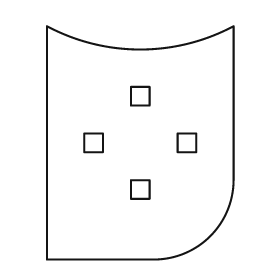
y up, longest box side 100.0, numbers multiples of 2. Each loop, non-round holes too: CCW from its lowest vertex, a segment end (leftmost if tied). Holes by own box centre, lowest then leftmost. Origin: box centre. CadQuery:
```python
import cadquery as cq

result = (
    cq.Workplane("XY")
    .moveTo(-40.0, -50.0)
    .lineTo(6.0, -50.0)
    .threePointArc((30.0, -40.0), (40.0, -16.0))
    .lineTo(40.0, 50.0)
    .threePointArc((0.0, 40.0), (-40.0, 50.0))
    .close()
    .moveTo(-4.0, -24.0)
    .lineTo(4.0, -24.0)
    .lineTo(4.0, -16.0)
    .lineTo(-4.0, -16.0)
    .close()
    .moveTo(-24.0, -4.0)
    .lineTo(-16.0, -4.0)
    .lineTo(-16.0, 4.0)
    .lineTo(-24.0, 4.0)
    .close()
    .moveTo(16.0, -4.0)
    .lineTo(24.0, -4.0)
    .lineTo(24.0, 4.0)
    .lineTo(16.0, 4.0)
    .close()
    .moveTo(-4.0, 16.0)
    .lineTo(4.0, 16.0)
    .lineTo(4.0, 24.0)
    .lineTo(-4.0, 24.0)
    .close()
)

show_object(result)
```